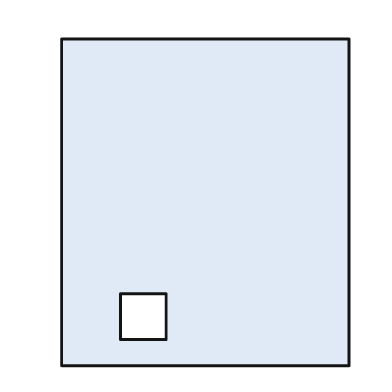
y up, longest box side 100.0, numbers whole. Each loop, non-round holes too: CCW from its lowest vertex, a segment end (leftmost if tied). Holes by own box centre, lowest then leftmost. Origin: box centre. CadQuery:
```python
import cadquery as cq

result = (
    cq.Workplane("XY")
    .moveTo(-44.0, -50.0)
    .lineTo(44.0, -50.0)
    .lineTo(44.0, 50.0)
    .lineTo(-44.0, 50.0)
    .close()
    .moveTo(-26.0, -42.0)
    .lineTo(-12.0, -42.0)
    .lineTo(-12.0, -28.0)
    .lineTo(-26.0, -28.0)
    .close()
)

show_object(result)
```